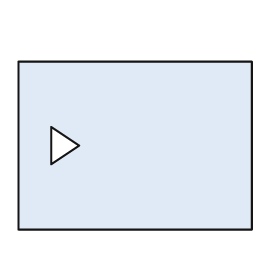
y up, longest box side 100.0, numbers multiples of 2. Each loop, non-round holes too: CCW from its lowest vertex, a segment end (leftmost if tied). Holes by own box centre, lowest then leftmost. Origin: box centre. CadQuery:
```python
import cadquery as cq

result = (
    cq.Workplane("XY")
    .moveTo(-50.0, -36.0)
    .lineTo(50.0, -36.0)
    .lineTo(50.0, 36.0)
    .lineTo(-50.0, 36.0)
    .close()
    .moveTo(-36.0, -8.0)
    .lineTo(-24.0, 0.0)
    .lineTo(-36.0, 8.0)
    .close()
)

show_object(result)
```